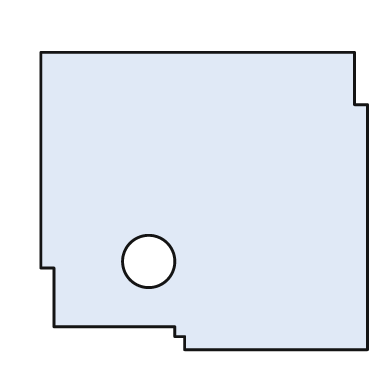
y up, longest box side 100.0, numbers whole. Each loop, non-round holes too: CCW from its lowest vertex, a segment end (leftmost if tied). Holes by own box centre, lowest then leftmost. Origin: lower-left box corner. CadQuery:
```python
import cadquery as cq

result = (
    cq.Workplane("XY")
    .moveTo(44.0, 0.0)
    .lineTo(100.0, 0.0)
    .lineTo(100.0, 75.0)
    .lineTo(96.0, 75.0)
    .lineTo(96.0, 91.0)
    .lineTo(0.0, 91.0)
    .lineTo(0.0, 25.0)
    .lineTo(4.0, 25.0)
    .lineTo(4.0, 7.0)
    .lineTo(41.0, 7.0)
    .lineTo(41.0, 4.0)
    .lineTo(44.0, 4.0)
    .close()
    .moveTo(33.0, 27.0)
    .circle(8.0)
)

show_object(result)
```